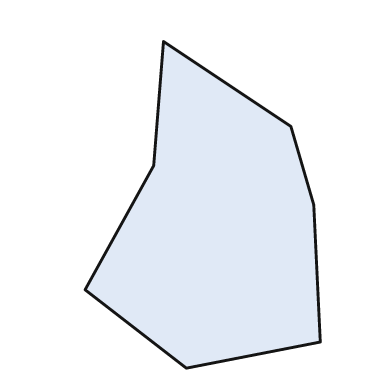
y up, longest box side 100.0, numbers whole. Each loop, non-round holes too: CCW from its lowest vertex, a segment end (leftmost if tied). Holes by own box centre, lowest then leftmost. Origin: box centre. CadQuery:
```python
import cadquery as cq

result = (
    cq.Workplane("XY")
    .moveTo(-5.0, -50.0)
    .lineTo(36.0, -42.0)
    .lineTo(34.0, 0.0)
    .lineTo(27.0, 24.0)
    .lineTo(-12.0, 50.0)
    .lineTo(-15.0, 12.0)
    .lineTo(-36.0, -26.0)
    .close()
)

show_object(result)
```